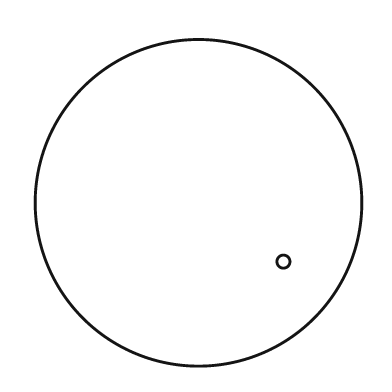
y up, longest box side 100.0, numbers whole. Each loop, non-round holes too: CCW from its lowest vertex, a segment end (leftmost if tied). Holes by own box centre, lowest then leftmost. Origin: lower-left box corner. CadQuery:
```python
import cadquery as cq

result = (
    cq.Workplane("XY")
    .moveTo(50.0, 50.0)
    .circle(50.0)
    .moveTo(76.0, 32.0)
    .circle(2.0)
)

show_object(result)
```